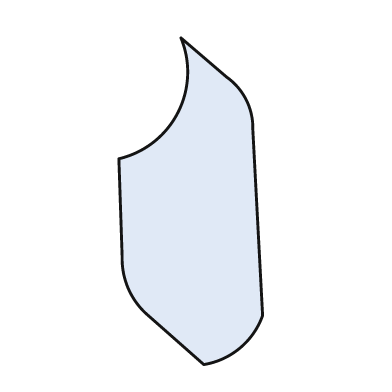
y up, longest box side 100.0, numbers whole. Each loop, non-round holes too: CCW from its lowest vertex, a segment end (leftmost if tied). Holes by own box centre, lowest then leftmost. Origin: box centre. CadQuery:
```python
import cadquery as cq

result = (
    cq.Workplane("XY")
    .moveTo(4.0, -50.0)
    .threePointArc((15.0, -45.0), (22.0, -35.0))
    .lineTo(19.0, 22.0)
    .threePointArc((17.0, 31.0), (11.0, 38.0))
    .lineTo(-3.0, 50.0)
    .threePointArc((-4.0, 27.0), (-22.0, 13.0))
    .lineTo(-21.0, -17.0)
    .threePointArc((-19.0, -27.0), (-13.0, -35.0))
    .close()
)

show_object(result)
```